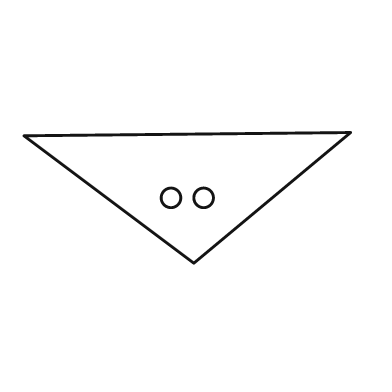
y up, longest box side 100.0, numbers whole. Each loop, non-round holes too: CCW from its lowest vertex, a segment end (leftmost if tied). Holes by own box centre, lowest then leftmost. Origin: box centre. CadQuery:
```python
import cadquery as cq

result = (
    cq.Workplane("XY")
    .moveTo(2.0, -20.0)
    .lineTo(50.0, 20.0)
    .lineTo(-50.0, 19.0)
    .close()
    .moveTo(-5.0, 0.0)
    .circle(3.0)
    .moveTo(5.0, 0.0)
    .circle(3.0)
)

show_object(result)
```